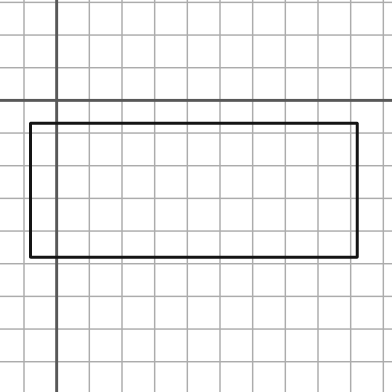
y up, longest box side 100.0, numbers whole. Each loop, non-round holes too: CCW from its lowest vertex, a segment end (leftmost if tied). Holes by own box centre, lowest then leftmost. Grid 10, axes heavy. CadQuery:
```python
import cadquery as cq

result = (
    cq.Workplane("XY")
    .moveTo(-8.0, -48.0)
    .lineTo(92.0, -48.0)
    .lineTo(92.0, -7.0)
    .lineTo(-8.0, -7.0)
    .close()
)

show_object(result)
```